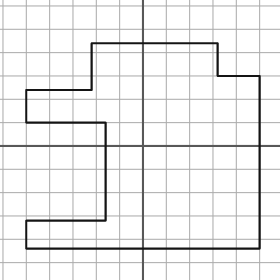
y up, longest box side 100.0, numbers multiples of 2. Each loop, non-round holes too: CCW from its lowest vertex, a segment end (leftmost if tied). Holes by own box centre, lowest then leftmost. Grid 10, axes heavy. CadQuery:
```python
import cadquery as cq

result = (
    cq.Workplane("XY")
    .moveTo(-50.0, -44.0)
    .lineTo(50.0, -44.0)
    .lineTo(50.0, 30.0)
    .lineTo(32.0, 30.0)
    .lineTo(32.0, 44.0)
    .lineTo(-22.0, 44.0)
    .lineTo(-22.0, 24.0)
    .lineTo(-50.0, 24.0)
    .lineTo(-50.0, 10.0)
    .lineTo(-16.0, 10.0)
    .lineTo(-16.0, -32.0)
    .lineTo(-50.0, -32.0)
    .close()
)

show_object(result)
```